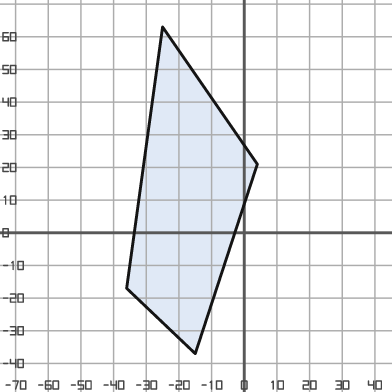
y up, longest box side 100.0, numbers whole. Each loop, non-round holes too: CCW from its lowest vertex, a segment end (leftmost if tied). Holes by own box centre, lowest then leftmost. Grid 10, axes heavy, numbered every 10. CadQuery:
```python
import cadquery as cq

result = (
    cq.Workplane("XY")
    .moveTo(-15.0, -37.0)
    .lineTo(4.0, 21.0)
    .lineTo(-25.0, 63.0)
    .lineTo(-36.0, -17.0)
    .close()
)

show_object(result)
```